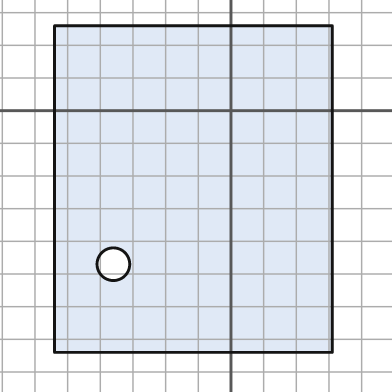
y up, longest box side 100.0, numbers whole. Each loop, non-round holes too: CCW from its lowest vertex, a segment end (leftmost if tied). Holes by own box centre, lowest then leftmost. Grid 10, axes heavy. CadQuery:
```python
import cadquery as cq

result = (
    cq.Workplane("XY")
    .moveTo(-54.0, -74.0)
    .lineTo(31.0, -74.0)
    .lineTo(31.0, 26.0)
    .lineTo(-54.0, 26.0)
    .close()
    .moveTo(-36.0, -47.0)
    .circle(5.0)
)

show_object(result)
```